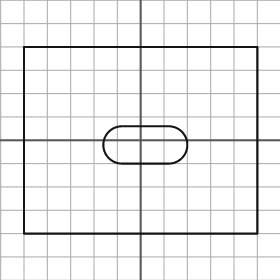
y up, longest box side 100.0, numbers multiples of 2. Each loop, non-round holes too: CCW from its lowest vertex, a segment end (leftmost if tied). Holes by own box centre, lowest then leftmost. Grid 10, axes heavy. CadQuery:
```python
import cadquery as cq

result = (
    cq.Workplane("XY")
    .moveTo(-50.0, -40.0)
    .lineTo(50.0, -40.0)
    .lineTo(50.0, 40.0)
    .lineTo(-50.0, 40.0)
    .close()
    .moveTo(-8.0, -10.0)
    .lineTo(12.0, -10.0)
    .threePointArc((20.0, -2.0), (12.0, 6.0))
    .lineTo(-8.0, 6.0)
    .threePointArc((-16.0, -2.0), (-8.0, -10.0))
    .close()
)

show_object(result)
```